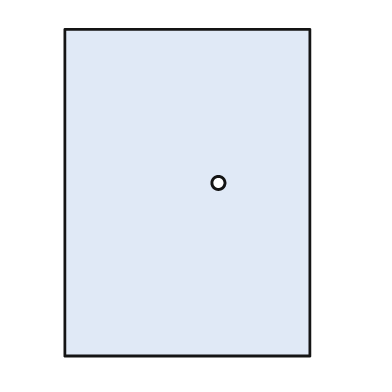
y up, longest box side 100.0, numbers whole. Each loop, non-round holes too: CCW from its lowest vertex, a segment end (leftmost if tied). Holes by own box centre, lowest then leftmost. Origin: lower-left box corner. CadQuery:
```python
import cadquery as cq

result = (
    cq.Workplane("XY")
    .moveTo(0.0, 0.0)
    .lineTo(75.0, 0.0)
    .lineTo(75.0, 100.0)
    .lineTo(0.0, 100.0)
    .close()
    .moveTo(47.0, 53.0)
    .circle(2.0)
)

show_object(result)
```